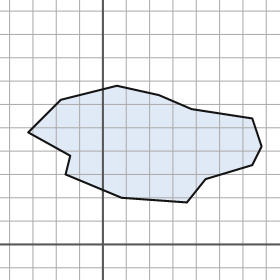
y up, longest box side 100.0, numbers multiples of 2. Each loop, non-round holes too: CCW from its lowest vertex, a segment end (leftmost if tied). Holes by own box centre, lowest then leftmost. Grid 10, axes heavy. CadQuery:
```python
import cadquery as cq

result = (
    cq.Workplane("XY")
    .moveTo(36.0, 18.0)
    .lineTo(44.0, 28.0)
    .lineTo(64.0, 34.0)
    .lineTo(68.0, 42.0)
    .lineTo(64.0, 54.0)
    .lineTo(38.0, 58.0)
    .lineTo(24.0, 64.0)
    .lineTo(6.0, 68.0)
    .lineTo(-18.0, 62.0)
    .lineTo(-32.0, 48.0)
    .lineTo(-14.0, 38.0)
    .lineTo(-16.0, 30.0)
    .lineTo(8.0, 20.0)
    .close()
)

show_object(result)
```